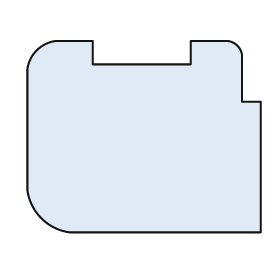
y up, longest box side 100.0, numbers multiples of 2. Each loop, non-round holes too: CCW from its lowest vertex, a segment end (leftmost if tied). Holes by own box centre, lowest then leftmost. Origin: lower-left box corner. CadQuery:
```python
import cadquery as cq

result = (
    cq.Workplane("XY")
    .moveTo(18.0, 0.0)
    .lineTo(100.0, 0.0)
    .lineTo(100.0, 56.0)
    .lineTo(92.0, 56.0)
    .lineTo(92.0, 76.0)
    .threePointArc((90.0, 80.0), (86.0, 82.0))
    .lineTo(70.0, 82.0)
    .lineTo(70.0, 72.0)
    .lineTo(28.0, 72.0)
    .lineTo(28.0, 82.0)
    .lineTo(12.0, 82.0)
    .threePointArc((4.0, 78.0), (0.0, 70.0))
    .lineTo(0.0, 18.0)
    .threePointArc((6.0, 6.0), (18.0, 0.0))
    .close()
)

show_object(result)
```